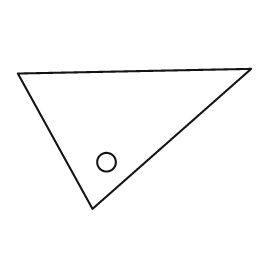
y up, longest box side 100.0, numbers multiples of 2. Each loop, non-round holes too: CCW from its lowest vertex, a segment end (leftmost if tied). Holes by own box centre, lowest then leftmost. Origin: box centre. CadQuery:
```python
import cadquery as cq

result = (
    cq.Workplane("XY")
    .moveTo(-18.0, -30.0)
    .lineTo(50.0, 30.0)
    .lineTo(-50.0, 28.0)
    .close()
    .moveTo(-12.0, -10.0)
    .circle(4.0)
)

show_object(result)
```